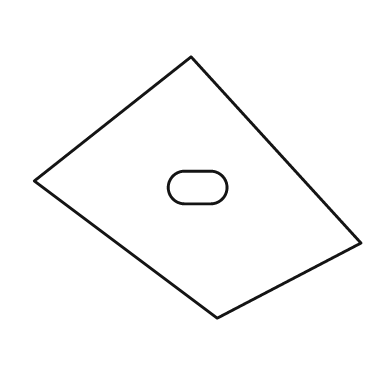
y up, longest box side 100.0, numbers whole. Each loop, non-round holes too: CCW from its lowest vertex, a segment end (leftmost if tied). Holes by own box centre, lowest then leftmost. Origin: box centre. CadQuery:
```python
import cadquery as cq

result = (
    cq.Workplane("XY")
    .moveTo(6.0, -40.0)
    .lineTo(50.0, -17.0)
    .lineTo(-2.0, 40.0)
    .lineTo(-50.0, 2.0)
    .close()
    .moveTo(-4.0, -5.0)
    .lineTo(4.0, -5.0)
    .threePointArc((9.0, 0.0), (4.0, 5.0))
    .lineTo(-4.0, 5.0)
    .threePointArc((-9.0, 0.0), (-4.0, -5.0))
    .close()
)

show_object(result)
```